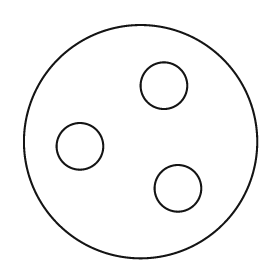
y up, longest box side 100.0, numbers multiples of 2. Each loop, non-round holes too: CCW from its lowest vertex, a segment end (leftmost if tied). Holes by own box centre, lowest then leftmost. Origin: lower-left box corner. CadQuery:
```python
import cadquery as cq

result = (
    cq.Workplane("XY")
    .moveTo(50.0, 50.0)
    .circle(50.0)
    .moveTo(66.0, 30.0)
    .circle(10.0)
    .moveTo(24.0, 48.0)
    .circle(10.0)
    .moveTo(60.0, 74.0)
    .circle(10.0)
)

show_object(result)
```